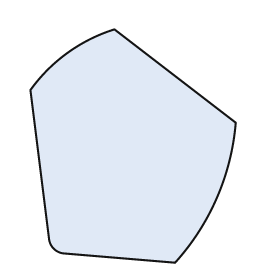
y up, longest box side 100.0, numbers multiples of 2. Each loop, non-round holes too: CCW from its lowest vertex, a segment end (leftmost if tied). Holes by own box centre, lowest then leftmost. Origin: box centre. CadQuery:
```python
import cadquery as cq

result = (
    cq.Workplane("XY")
    .moveTo(18.0, -50.0)
    .threePointArc((36.0, -22.0), (44.0, 10.0))
    .lineTo(-8.0, 50.0)
    .threePointArc((-28.0, 40.0), (-44.0, 24.0))
    .lineTo(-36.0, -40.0)
    .threePointArc((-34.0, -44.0), (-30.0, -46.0))
    .close()
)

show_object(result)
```